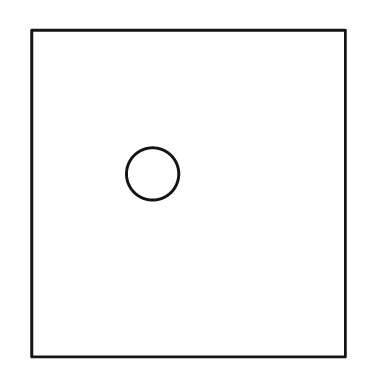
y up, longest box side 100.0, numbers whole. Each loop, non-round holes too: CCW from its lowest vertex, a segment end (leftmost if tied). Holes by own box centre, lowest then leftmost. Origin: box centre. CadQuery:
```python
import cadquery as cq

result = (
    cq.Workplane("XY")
    .moveTo(-48.0, -50.0)
    .lineTo(48.0, -50.0)
    .lineTo(48.0, 50.0)
    .lineTo(-48.0, 50.0)
    .close()
    .moveTo(-11.0, 6.0)
    .circle(8.0)
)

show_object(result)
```